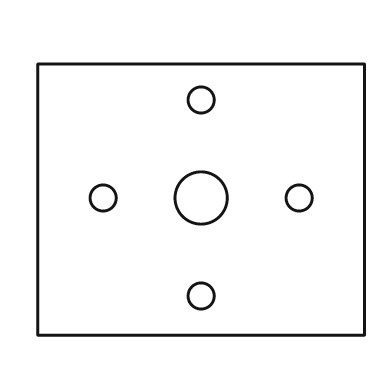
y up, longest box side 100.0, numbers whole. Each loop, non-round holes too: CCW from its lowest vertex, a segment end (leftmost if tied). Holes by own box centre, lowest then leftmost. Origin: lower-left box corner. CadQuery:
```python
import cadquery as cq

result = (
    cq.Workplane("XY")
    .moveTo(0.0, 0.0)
    .lineTo(100.0, 0.0)
    .lineTo(100.0, 83.0)
    .lineTo(0.0, 83.0)
    .close()
    .moveTo(50.0, 12.0)
    .circle(4.0)
    .moveTo(20.0, 42.0)
    .circle(4.0)
    .moveTo(50.0, 42.0)
    .circle(8.0)
    .moveTo(80.0, 42.0)
    .circle(4.0)
    .moveTo(50.0, 72.0)
    .circle(4.0)
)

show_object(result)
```